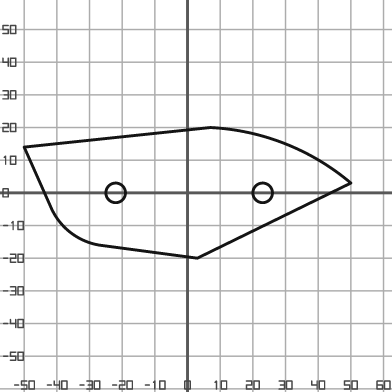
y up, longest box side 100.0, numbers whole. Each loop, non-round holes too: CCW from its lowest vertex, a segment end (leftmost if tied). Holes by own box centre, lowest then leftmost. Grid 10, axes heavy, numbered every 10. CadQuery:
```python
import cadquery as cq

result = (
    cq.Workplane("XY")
    .moveTo(3.0, -20.0)
    .lineTo(50.0, 3.0)
    .threePointArc((30.0, 15.0), (7.0, 20.0))
    .lineTo(-50.0, 14.0)
    .lineTo(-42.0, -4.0)
    .threePointArc((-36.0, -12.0), (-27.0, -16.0))
    .close()
    .moveTo(-22.0, 0.0)
    .circle(3.0)
    .moveTo(23.0, 0.0)
    .circle(3.0)
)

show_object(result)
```